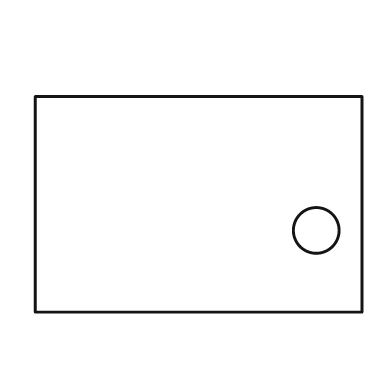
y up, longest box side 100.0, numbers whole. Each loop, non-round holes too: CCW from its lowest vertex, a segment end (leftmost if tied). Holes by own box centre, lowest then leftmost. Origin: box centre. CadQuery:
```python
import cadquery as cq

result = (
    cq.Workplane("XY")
    .moveTo(-50.0, -33.0)
    .lineTo(50.0, -33.0)
    .lineTo(50.0, 33.0)
    .lineTo(-50.0, 33.0)
    .close()
    .moveTo(36.0, -8.0)
    .circle(7.0)
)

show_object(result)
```